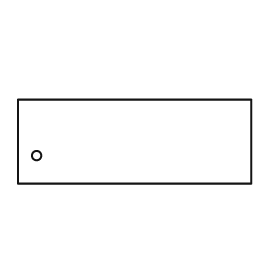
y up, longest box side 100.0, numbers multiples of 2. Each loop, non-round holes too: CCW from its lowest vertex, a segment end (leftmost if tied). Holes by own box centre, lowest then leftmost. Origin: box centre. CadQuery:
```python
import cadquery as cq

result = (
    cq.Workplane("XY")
    .moveTo(-50.0, -18.0)
    .lineTo(50.0, -18.0)
    .lineTo(50.0, 18.0)
    .lineTo(-50.0, 18.0)
    .close()
    .moveTo(-42.0, -6.0)
    .circle(2.0)
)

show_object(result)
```